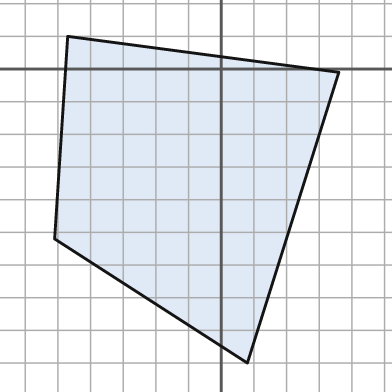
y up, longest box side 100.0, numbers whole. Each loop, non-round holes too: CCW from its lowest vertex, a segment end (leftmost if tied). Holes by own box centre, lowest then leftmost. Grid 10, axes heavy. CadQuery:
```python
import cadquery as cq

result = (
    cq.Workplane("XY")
    .moveTo(8.0, -90.0)
    .lineTo(36.0, -1.0)
    .lineTo(-47.0, 10.0)
    .lineTo(-51.0, -52.0)
    .close()
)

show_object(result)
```